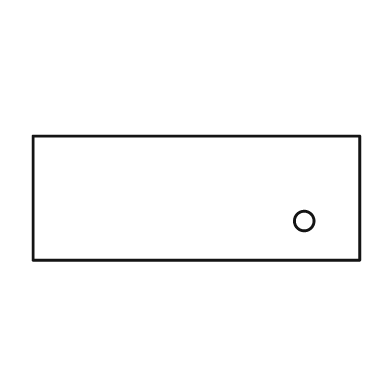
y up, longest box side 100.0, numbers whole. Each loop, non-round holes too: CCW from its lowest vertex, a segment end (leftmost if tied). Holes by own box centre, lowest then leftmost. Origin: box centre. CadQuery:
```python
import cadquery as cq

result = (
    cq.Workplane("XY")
    .moveTo(-50.0, -19.0)
    .lineTo(50.0, -19.0)
    .lineTo(50.0, 19.0)
    .lineTo(-50.0, 19.0)
    .close()
    .moveTo(33.0, -7.0)
    .circle(3.0)
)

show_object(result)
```